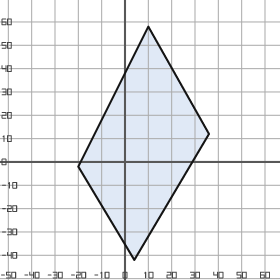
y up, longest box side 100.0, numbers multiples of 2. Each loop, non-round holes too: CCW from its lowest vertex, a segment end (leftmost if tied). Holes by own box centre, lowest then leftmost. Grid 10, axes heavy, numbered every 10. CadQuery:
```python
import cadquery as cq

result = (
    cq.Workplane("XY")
    .moveTo(4.0, -42.0)
    .lineTo(36.0, 12.0)
    .lineTo(10.0, 58.0)
    .lineTo(-20.0, -2.0)
    .close()
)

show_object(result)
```